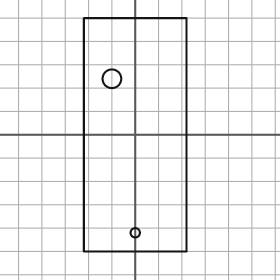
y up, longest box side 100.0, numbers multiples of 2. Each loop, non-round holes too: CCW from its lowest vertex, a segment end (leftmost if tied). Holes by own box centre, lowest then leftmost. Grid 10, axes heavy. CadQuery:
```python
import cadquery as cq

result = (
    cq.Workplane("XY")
    .moveTo(-22.0, -50.0)
    .lineTo(22.0, -50.0)
    .lineTo(22.0, 50.0)
    .lineTo(-22.0, 50.0)
    .close()
    .moveTo(0.0, -42.0)
    .circle(2.0)
    .moveTo(-10.0, 24.0)
    .circle(4.0)
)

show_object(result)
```